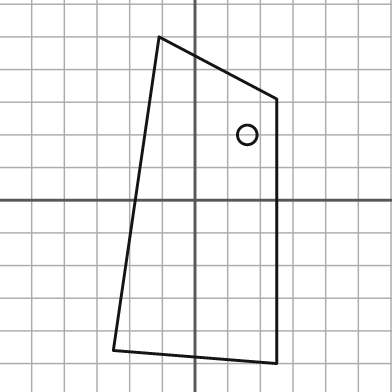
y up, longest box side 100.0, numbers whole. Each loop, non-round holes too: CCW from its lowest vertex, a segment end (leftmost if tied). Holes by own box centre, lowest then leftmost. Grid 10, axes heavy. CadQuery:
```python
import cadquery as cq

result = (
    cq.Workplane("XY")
    .moveTo(25.0, -50.0)
    .lineTo(25.0, 31.0)
    .lineTo(-11.0, 50.0)
    .lineTo(-25.0, -46.0)
    .close()
    .moveTo(16.0, 20.0)
    .circle(3.0)
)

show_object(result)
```